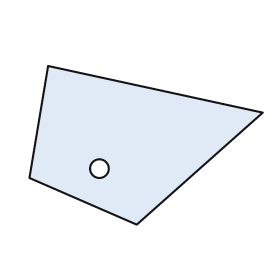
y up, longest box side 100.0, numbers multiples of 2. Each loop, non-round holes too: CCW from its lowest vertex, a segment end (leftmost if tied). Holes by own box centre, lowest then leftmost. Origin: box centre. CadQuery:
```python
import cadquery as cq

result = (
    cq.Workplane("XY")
    .moveTo(-4.0, -34.0)
    .lineTo(50.0, 14.0)
    .lineTo(-42.0, 34.0)
    .lineTo(-50.0, -14.0)
    .close()
    .moveTo(-20.0, -10.0)
    .circle(4.0)
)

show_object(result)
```